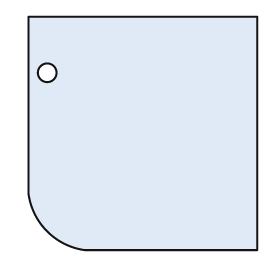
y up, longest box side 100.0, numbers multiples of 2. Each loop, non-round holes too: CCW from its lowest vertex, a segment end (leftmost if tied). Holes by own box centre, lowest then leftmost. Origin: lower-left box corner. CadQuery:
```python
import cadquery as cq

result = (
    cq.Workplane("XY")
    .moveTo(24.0, 0.0)
    .lineTo(98.0, 0.0)
    .lineTo(98.0, 100.0)
    .lineTo(0.0, 100.0)
    .lineTo(0.0, 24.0)
    .threePointArc((8.0, 8.0), (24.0, 0.0))
    .close()
    .moveTo(8.0, 76.0)
    .circle(4.0)
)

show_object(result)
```